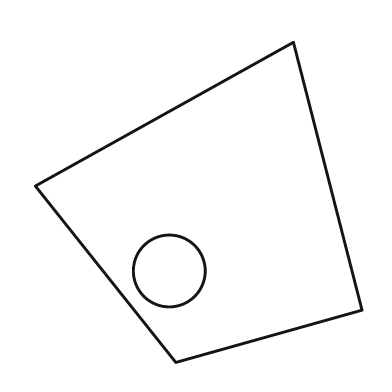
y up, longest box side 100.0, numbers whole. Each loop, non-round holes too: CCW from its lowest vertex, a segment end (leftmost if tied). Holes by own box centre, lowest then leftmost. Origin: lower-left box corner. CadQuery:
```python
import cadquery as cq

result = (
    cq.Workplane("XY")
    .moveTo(43.0, 0.0)
    .lineTo(100.0, 16.0)
    .lineTo(79.0, 98.0)
    .lineTo(0.0, 54.0)
    .close()
    .moveTo(41.0, 28.0)
    .circle(11.0)
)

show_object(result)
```